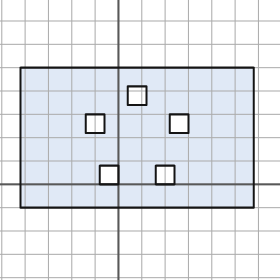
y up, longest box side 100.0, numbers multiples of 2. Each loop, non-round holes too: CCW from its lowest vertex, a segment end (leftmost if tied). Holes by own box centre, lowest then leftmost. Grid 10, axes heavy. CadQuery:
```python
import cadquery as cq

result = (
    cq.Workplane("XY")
    .moveTo(-42.0, -10.0)
    .lineTo(58.0, -10.0)
    .lineTo(58.0, 50.0)
    .lineTo(-42.0, 50.0)
    .close()
    .moveTo(-8.0, 0.0)
    .lineTo(0.0, 0.0)
    .lineTo(0.0, 8.0)
    .lineTo(-8.0, 8.0)
    .close()
    .moveTo(16.0, 0.0)
    .lineTo(24.0, 0.0)
    .lineTo(24.0, 8.0)
    .lineTo(16.0, 8.0)
    .close()
    .moveTo(-14.0, 22.0)
    .lineTo(-6.0, 22.0)
    .lineTo(-6.0, 30.0)
    .lineTo(-14.0, 30.0)
    .close()
    .moveTo(22.0, 22.0)
    .lineTo(30.0, 22.0)
    .lineTo(30.0, 30.0)
    .lineTo(22.0, 30.0)
    .close()
    .moveTo(4.0, 34.0)
    .lineTo(12.0, 34.0)
    .lineTo(12.0, 42.0)
    .lineTo(4.0, 42.0)
    .close()
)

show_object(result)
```